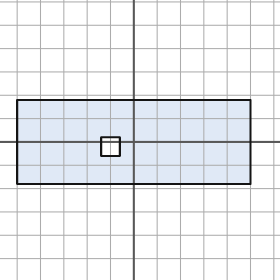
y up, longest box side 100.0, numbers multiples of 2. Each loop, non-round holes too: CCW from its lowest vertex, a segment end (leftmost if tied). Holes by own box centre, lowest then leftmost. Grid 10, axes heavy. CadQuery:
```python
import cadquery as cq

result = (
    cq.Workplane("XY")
    .moveTo(-50.0, -18.0)
    .lineTo(50.0, -18.0)
    .lineTo(50.0, 18.0)
    .lineTo(-50.0, 18.0)
    .close()
    .moveTo(-14.0, -6.0)
    .lineTo(-6.0, -6.0)
    .lineTo(-6.0, 2.0)
    .lineTo(-14.0, 2.0)
    .close()
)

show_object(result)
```